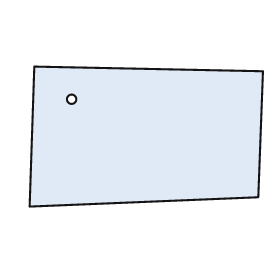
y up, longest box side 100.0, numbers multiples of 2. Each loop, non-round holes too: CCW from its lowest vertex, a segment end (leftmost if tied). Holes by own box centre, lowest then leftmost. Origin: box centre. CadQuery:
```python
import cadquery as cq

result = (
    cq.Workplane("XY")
    .moveTo(-50.0, -30.0)
    .lineTo(48.0, -26.0)
    .lineTo(50.0, 28.0)
    .lineTo(-48.0, 30.0)
    .close()
    .moveTo(-32.0, 16.0)
    .circle(2.0)
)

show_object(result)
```